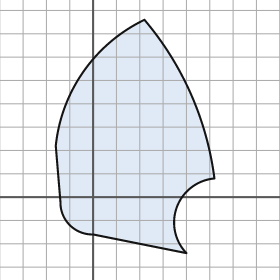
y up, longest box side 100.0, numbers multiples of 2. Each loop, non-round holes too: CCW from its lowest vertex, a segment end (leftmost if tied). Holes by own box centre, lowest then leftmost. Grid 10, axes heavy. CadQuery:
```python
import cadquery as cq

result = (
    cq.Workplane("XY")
    .moveTo(40.0, -24.0)
    .threePointArc((36.0, -4.0), (52.0, 8.0))
    .threePointArc((42.0, 44.0), (22.0, 76.0))
    .threePointArc((-4.0, 54.0), (-16.0, 22.0))
    .lineTo(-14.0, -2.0)
    .threePointArc((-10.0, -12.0), (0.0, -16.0))
    .close()
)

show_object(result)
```